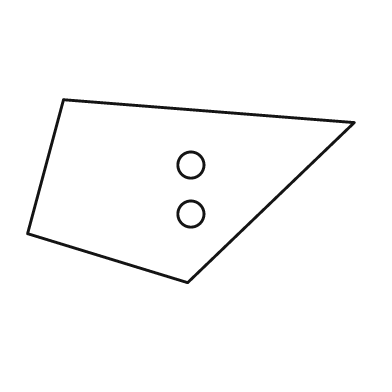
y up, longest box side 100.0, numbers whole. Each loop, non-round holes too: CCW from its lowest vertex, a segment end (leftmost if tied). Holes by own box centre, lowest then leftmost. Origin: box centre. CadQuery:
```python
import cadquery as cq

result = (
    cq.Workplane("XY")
    .moveTo(-1.0, -28.0)
    .lineTo(50.0, 21.0)
    .lineTo(-39.0, 28.0)
    .lineTo(-50.0, -13.0)
    .close()
    .moveTo(0.0, -7.0)
    .circle(4.0)
    .moveTo(0.0, 8.0)
    .circle(4.0)
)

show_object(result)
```